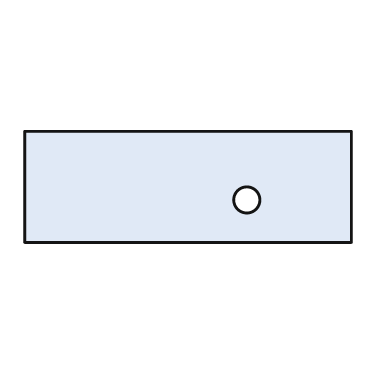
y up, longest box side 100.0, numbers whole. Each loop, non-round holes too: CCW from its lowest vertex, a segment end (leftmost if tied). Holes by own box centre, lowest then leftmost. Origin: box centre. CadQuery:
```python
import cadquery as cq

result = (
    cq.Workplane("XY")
    .moveTo(-50.0, -17.0)
    .lineTo(50.0, -17.0)
    .lineTo(50.0, 17.0)
    .lineTo(-50.0, 17.0)
    .close()
    .moveTo(18.0, -4.0)
    .circle(4.0)
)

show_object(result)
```